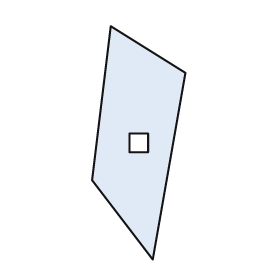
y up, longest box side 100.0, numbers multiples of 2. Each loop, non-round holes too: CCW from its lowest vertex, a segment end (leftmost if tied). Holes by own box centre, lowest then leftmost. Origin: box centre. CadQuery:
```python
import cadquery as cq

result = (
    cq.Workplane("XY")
    .moveTo(6.0, -50.0)
    .lineTo(20.0, 30.0)
    .lineTo(-12.0, 50.0)
    .lineTo(-20.0, -16.0)
    .close()
    .moveTo(-4.0, -4.0)
    .lineTo(4.0, -4.0)
    .lineTo(4.0, 4.0)
    .lineTo(-4.0, 4.0)
    .close()
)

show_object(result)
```